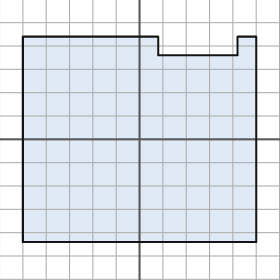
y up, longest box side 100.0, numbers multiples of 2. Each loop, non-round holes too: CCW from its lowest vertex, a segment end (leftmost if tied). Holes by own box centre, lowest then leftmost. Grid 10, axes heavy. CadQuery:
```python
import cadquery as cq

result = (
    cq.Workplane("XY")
    .moveTo(-50.0, -44.0)
    .lineTo(50.0, -44.0)
    .lineTo(50.0, 44.0)
    .lineTo(42.0, 44.0)
    .lineTo(42.0, 36.0)
    .lineTo(8.0, 36.0)
    .lineTo(8.0, 44.0)
    .lineTo(-50.0, 44.0)
    .close()
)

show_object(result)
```